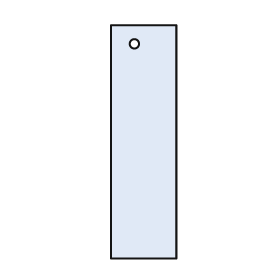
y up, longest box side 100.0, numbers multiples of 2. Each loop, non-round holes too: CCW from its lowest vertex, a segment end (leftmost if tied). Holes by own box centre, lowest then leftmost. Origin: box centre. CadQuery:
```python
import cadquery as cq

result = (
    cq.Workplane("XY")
    .moveTo(-14.0, -50.0)
    .lineTo(14.0, -50.0)
    .lineTo(14.0, 50.0)
    .lineTo(-14.0, 50.0)
    .close()
    .moveTo(-4.0, 42.0)
    .circle(2.0)
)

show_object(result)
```